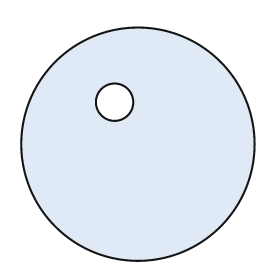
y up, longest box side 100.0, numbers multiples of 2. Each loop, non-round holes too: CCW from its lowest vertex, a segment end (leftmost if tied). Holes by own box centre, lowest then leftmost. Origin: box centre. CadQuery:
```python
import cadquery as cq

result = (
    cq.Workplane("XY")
    .moveTo(0.0, 0.0)
    .circle(50.0)
    .moveTo(-10.0, 18.0)
    .circle(8.0)
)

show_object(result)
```